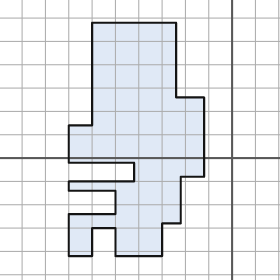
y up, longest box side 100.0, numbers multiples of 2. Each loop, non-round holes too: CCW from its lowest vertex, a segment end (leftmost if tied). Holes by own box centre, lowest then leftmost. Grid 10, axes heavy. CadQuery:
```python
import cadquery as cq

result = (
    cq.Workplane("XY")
    .moveTo(-70.0, -42.0)
    .lineTo(-60.0, -42.0)
    .lineTo(-60.0, -30.0)
    .lineTo(-50.0, -30.0)
    .lineTo(-50.0, -42.0)
    .lineTo(-30.0, -42.0)
    .lineTo(-30.0, -28.0)
    .lineTo(-22.0, -28.0)
    .lineTo(-22.0, -8.0)
    .lineTo(-12.0, -8.0)
    .lineTo(-12.0, 26.0)
    .lineTo(-24.0, 26.0)
    .lineTo(-24.0, 58.0)
    .lineTo(-60.0, 58.0)
    .lineTo(-60.0, 14.0)
    .lineTo(-70.0, 14.0)
    .lineTo(-70.0, -2.0)
    .lineTo(-42.0, -2.0)
    .lineTo(-42.0, -10.0)
    .lineTo(-70.0, -10.0)
    .lineTo(-70.0, -14.0)
    .lineTo(-50.0, -14.0)
    .lineTo(-50.0, -24.0)
    .lineTo(-70.0, -24.0)
    .close()
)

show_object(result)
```